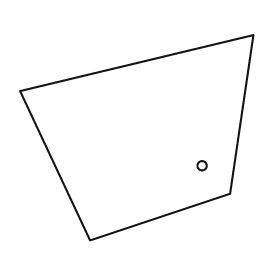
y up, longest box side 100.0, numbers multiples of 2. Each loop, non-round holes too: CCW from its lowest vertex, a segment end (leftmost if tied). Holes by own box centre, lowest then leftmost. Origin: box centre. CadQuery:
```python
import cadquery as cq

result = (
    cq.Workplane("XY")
    .moveTo(-20.0, -44.0)
    .lineTo(40.0, -24.0)
    .lineTo(50.0, 44.0)
    .lineTo(-50.0, 20.0)
    .close()
    .moveTo(28.0, -12.0)
    .circle(2.0)
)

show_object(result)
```